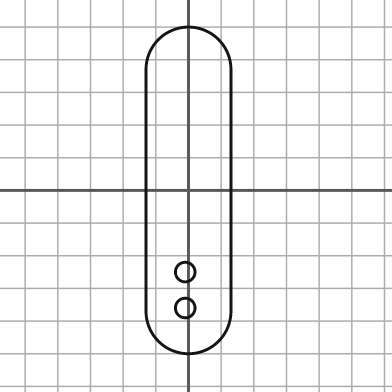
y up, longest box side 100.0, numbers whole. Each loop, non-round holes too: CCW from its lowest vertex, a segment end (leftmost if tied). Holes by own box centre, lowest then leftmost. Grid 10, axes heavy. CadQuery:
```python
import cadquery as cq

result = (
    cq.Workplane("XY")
    .moveTo(-13.0, -37.0)
    .threePointArc((0.0, -50.0), (13.0, -37.0))
    .lineTo(13.0, 37.0)
    .threePointArc((0.0, 50.0), (-13.0, 37.0))
    .close()
    .moveTo(-1.0, -36.0)
    .circle(3.0)
    .moveTo(-1.0, -25.0)
    .circle(3.0)
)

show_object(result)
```